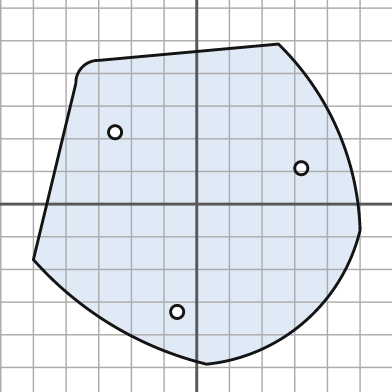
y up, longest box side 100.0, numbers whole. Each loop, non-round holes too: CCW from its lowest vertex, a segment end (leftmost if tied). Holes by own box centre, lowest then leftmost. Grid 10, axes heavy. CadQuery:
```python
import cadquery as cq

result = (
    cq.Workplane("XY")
    .moveTo(3.0, -49.0)
    .threePointArc((33.0, -36.0), (50.0, -8.0))
    .threePointArc((43.0, 23.0), (25.0, 49.0))
    .lineTo(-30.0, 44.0)
    .threePointArc((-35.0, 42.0), (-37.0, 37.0))
    .lineTo(-50.0, -17.0)
    .threePointArc((-26.0, -37.0), (3.0, -49.0))
    .close()
    .moveTo(-6.0, -33.0)
    .circle(2.0)
    .moveTo(32.0, 11.0)
    .circle(2.0)
    .moveTo(-25.0, 22.0)
    .circle(2.0)
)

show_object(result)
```